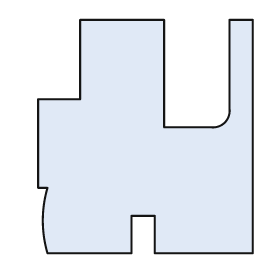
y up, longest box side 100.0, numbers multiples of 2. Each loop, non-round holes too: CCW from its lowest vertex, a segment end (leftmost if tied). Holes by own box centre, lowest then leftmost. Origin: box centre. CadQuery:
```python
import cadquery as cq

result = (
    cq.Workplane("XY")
    .moveTo(-42.0, -50.0)
    .lineTo(-6.0, -50.0)
    .lineTo(-6.0, -34.0)
    .lineTo(4.0, -34.0)
    .lineTo(4.0, -50.0)
    .lineTo(46.0, -50.0)
    .lineTo(46.0, 50.0)
    .lineTo(36.0, 50.0)
    .lineTo(36.0, 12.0)
    .threePointArc((34.0, 6.0), (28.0, 4.0))
    .lineTo(8.0, 4.0)
    .lineTo(8.0, 50.0)
    .lineTo(-28.0, 50.0)
    .lineTo(-28.0, 16.0)
    .lineTo(-46.0, 16.0)
    .lineTo(-46.0, -22.0)
    .lineTo(-42.0, -22.0)
    .threePointArc((-44.0, -36.0), (-42.0, -50.0))
    .close()
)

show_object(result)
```